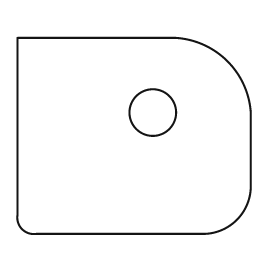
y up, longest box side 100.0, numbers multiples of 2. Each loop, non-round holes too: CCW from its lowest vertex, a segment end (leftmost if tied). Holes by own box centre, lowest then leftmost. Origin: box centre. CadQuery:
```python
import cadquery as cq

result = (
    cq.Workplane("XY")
    .moveTo(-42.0, -42.0)
    .lineTo(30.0, -42.0)
    .threePointArc((44.0, -36.0), (50.0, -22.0))
    .lineTo(50.0, 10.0)
    .threePointArc((40.0, 32.0), (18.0, 42.0))
    .lineTo(-50.0, 42.0)
    .lineTo(-50.0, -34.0)
    .threePointArc((-48.0, -40.0), (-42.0, -42.0))
    .close()
    .moveTo(8.0, 10.0)
    .circle(10.0)
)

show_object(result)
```